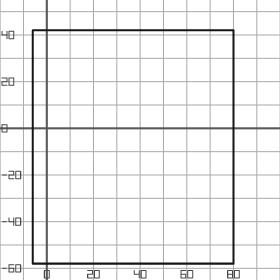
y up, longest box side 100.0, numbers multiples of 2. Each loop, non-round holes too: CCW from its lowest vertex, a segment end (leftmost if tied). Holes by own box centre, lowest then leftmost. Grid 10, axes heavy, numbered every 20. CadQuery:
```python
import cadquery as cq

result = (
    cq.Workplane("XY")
    .moveTo(-6.0, -58.0)
    .lineTo(80.0, -58.0)
    .lineTo(80.0, 42.0)
    .lineTo(-6.0, 42.0)
    .close()
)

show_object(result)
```